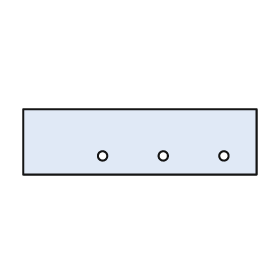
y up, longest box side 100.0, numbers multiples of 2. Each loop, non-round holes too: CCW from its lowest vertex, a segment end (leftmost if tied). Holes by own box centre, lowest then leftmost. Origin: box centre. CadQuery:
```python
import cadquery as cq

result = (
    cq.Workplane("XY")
    .moveTo(-50.0, -14.0)
    .lineTo(50.0, -14.0)
    .lineTo(50.0, 14.0)
    .lineTo(-50.0, 14.0)
    .close()
    .moveTo(-16.0, -6.0)
    .circle(2.0)
    .moveTo(10.0, -6.0)
    .circle(2.0)
    .moveTo(36.0, -6.0)
    .circle(2.0)
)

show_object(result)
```